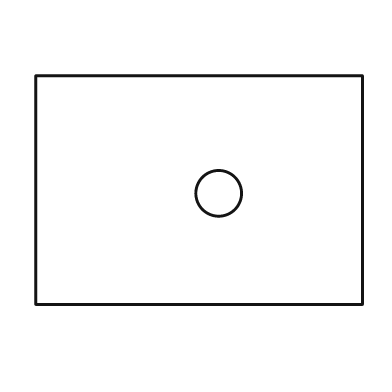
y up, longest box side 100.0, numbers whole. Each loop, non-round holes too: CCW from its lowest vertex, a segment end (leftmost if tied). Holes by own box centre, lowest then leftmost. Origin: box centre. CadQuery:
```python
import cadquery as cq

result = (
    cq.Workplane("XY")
    .moveTo(-50.0, -35.0)
    .lineTo(50.0, -35.0)
    .lineTo(50.0, 35.0)
    .lineTo(-50.0, 35.0)
    .close()
    .moveTo(6.0, -1.0)
    .circle(7.0)
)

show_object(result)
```